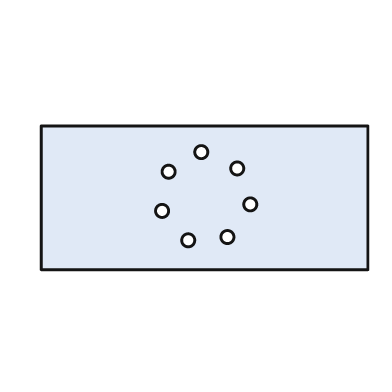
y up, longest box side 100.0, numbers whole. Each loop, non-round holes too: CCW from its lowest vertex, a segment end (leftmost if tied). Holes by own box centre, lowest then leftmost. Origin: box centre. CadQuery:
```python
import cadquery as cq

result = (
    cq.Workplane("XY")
    .moveTo(-50.0, -22.0)
    .lineTo(50.0, -22.0)
    .lineTo(50.0, 22.0)
    .lineTo(-50.0, 22.0)
    .close()
    .moveTo(-5.0, -13.0)
    .circle(2.0)
    .moveTo(7.0, -12.0)
    .circle(2.0)
    .moveTo(-13.0, -4.0)
    .circle(2.0)
    .moveTo(14.0, -2.0)
    .circle(2.0)
    .moveTo(-11.0, 8.0)
    .circle(2.0)
    .moveTo(10.0, 9.0)
    .circle(2.0)
    .moveTo(-1.0, 14.0)
    .circle(2.0)
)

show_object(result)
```